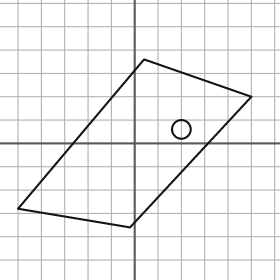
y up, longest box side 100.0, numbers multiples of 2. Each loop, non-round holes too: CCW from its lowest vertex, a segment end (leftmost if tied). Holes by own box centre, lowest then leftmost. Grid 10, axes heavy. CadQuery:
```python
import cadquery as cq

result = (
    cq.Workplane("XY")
    .moveTo(-2.0, -36.0)
    .lineTo(50.0, 20.0)
    .lineTo(4.0, 36.0)
    .lineTo(-50.0, -28.0)
    .close()
    .moveTo(20.0, 6.0)
    .circle(4.0)
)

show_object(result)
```